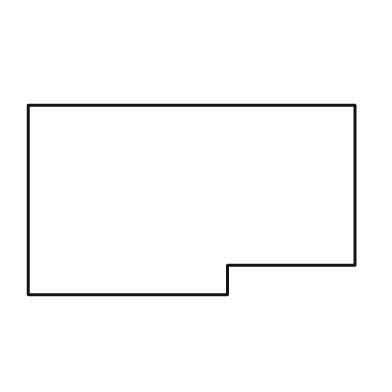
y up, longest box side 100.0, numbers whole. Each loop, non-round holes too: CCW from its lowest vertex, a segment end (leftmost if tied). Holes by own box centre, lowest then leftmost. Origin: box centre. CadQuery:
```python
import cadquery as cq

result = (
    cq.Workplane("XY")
    .moveTo(-50.0, -29.0)
    .lineTo(11.0, -29.0)
    .lineTo(11.0, -20.0)
    .lineTo(50.0, -20.0)
    .lineTo(50.0, 29.0)
    .lineTo(-50.0, 29.0)
    .close()
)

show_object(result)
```